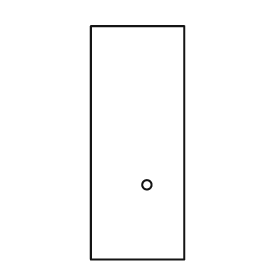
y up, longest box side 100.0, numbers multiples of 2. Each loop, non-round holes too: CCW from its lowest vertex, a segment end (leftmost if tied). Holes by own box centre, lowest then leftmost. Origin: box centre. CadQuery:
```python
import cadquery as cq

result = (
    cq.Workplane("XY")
    .moveTo(-20.0, -50.0)
    .lineTo(20.0, -50.0)
    .lineTo(20.0, 50.0)
    .lineTo(-20.0, 50.0)
    .close()
    .moveTo(4.0, -18.0)
    .circle(2.0)
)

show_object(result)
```